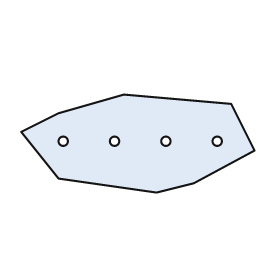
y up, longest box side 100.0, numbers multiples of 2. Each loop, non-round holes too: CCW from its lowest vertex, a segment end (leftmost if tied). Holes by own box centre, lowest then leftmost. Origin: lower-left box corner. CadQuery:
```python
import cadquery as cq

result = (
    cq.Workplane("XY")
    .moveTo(58.0, 0.0)
    .lineTo(74.0, 4.0)
    .lineTo(100.0, 18.0)
    .lineTo(90.0, 38.0)
    .lineTo(44.0, 42.0)
    .lineTo(16.0, 34.0)
    .lineTo(0.0, 26.0)
    .lineTo(16.0, 6.0)
    .close()
    .moveTo(18.0, 22.0)
    .circle(2.0)
    .moveTo(40.0, 22.0)
    .circle(2.0)
    .moveTo(62.0, 22.0)
    .circle(2.0)
    .moveTo(84.0, 22.0)
    .circle(2.0)
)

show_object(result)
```